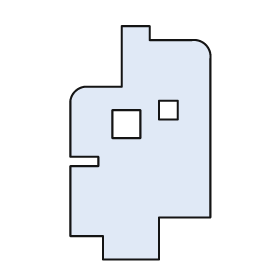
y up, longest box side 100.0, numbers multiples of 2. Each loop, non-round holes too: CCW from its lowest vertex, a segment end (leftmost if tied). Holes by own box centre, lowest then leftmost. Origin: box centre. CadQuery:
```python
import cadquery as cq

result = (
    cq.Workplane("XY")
    .moveTo(-16.0, -50.0)
    .lineTo(8.0, -50.0)
    .lineTo(8.0, -32.0)
    .lineTo(30.0, -32.0)
    .lineTo(30.0, 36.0)
    .threePointArc((28.0, 42.0), (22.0, 44.0))
    .lineTo(4.0, 44.0)
    .lineTo(4.0, 50.0)
    .lineTo(-8.0, 50.0)
    .lineTo(-8.0, 24.0)
    .lineTo(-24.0, 24.0)
    .threePointArc((-28.0, 22.0), (-30.0, 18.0))
    .lineTo(-30.0, -6.0)
    .lineTo(-18.0, -6.0)
    .lineTo(-18.0, -10.0)
    .lineTo(-30.0, -10.0)
    .lineTo(-30.0, -40.0)
    .lineTo(-16.0, -40.0)
    .close()
    .moveTo(-12.0, 2.0)
    .lineTo(0.0, 2.0)
    .lineTo(0.0, 14.0)
    .lineTo(-12.0, 14.0)
    .close()
    .moveTo(8.0, 10.0)
    .lineTo(16.0, 10.0)
    .lineTo(16.0, 18.0)
    .lineTo(8.0, 18.0)
    .close()
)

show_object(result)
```